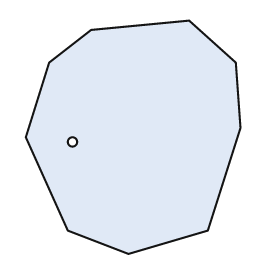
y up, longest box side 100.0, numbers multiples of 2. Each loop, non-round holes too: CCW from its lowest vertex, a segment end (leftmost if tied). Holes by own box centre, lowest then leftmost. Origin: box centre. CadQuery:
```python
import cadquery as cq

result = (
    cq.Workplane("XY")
    .moveTo(-2.0, -50.0)
    .lineTo(32.0, -40.0)
    .lineTo(46.0, 4.0)
    .lineTo(44.0, 32.0)
    .lineTo(24.0, 50.0)
    .lineTo(-18.0, 46.0)
    .lineTo(-36.0, 32.0)
    .lineTo(-46.0, 0.0)
    .lineTo(-28.0, -40.0)
    .close()
    .moveTo(-26.0, -2.0)
    .circle(2.0)
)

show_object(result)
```